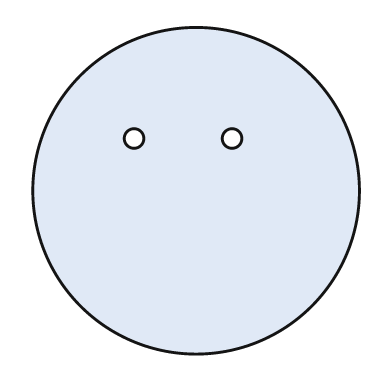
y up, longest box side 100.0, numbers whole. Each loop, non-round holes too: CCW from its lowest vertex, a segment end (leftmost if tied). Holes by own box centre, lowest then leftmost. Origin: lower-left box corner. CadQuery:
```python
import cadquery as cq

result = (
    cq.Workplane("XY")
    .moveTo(50.0, 50.0)
    .circle(50.0)
    .moveTo(31.0, 66.0)
    .circle(3.0)
    .moveTo(61.0, 66.0)
    .circle(3.0)
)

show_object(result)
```